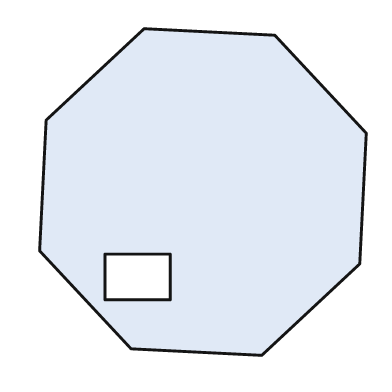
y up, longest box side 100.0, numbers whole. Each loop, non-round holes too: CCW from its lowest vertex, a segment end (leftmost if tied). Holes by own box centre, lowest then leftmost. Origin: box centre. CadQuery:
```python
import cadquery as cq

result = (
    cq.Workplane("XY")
    .moveTo(18.0, -50.0)
    .lineTo(48.0, -22.0)
    .lineTo(50.0, 18.0)
    .lineTo(22.0, 48.0)
    .lineTo(-18.0, 50.0)
    .lineTo(-48.0, 22.0)
    .lineTo(-50.0, -18.0)
    .lineTo(-22.0, -48.0)
    .close()
    .moveTo(-30.0, -33.0)
    .lineTo(-10.0, -33.0)
    .lineTo(-10.0, -19.0)
    .lineTo(-30.0, -19.0)
    .close()
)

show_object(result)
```